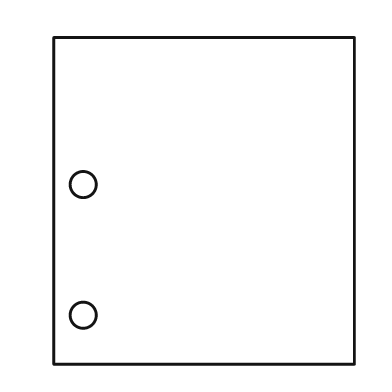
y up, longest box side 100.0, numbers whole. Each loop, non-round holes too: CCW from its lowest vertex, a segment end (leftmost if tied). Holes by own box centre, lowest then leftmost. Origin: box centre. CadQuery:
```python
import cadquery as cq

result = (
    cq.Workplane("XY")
    .moveTo(-46.0, -50.0)
    .lineTo(46.0, -50.0)
    .lineTo(46.0, 50.0)
    .lineTo(-46.0, 50.0)
    .close()
    .moveTo(-37.0, -35.0)
    .circle(4.0)
    .moveTo(-37.0, 5.0)
    .circle(4.0)
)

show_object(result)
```